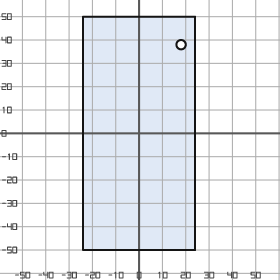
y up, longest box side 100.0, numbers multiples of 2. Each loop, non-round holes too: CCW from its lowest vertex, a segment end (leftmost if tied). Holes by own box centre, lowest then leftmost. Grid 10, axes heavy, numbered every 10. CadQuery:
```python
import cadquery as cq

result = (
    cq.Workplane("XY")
    .moveTo(-24.0, -50.0)
    .lineTo(24.0, -50.0)
    .lineTo(24.0, 50.0)
    .lineTo(-24.0, 50.0)
    .close()
    .moveTo(18.0, 38.0)
    .circle(2.0)
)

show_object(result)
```